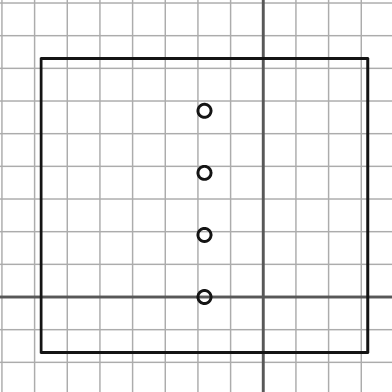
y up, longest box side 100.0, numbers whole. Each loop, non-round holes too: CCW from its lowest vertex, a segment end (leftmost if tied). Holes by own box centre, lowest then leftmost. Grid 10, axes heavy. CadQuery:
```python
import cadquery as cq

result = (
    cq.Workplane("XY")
    .moveTo(-68.0, -17.0)
    .lineTo(32.0, -17.0)
    .lineTo(32.0, 73.0)
    .lineTo(-68.0, 73.0)
    .close()
    .moveTo(-18.0, 0.0)
    .circle(2.0)
    .moveTo(-18.0, 19.0)
    .circle(2.0)
    .moveTo(-18.0, 38.0)
    .circle(2.0)
    .moveTo(-18.0, 57.0)
    .circle(2.0)
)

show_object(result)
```